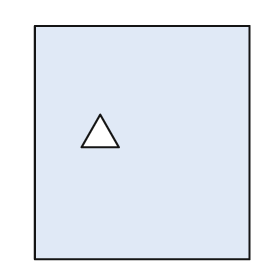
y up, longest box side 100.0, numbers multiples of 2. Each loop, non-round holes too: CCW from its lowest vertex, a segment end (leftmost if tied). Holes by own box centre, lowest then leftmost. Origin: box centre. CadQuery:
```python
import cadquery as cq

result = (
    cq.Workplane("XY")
    .moveTo(-46.0, -50.0)
    .lineTo(46.0, -50.0)
    .lineTo(46.0, 50.0)
    .lineTo(-46.0, 50.0)
    .close()
    .moveTo(-26.0, -2.0)
    .lineTo(-10.0, -2.0)
    .lineTo(-18.0, 12.0)
    .close()
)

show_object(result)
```